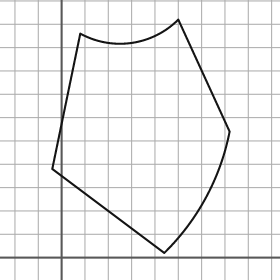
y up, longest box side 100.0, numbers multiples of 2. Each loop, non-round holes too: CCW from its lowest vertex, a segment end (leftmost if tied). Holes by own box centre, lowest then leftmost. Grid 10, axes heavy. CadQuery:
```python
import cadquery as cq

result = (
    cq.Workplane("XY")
    .moveTo(44.0, 2.0)
    .threePointArc((62.0, 26.0), (72.0, 54.0))
    .lineTo(50.0, 102.0)
    .threePointArc((30.0, 92.0), (8.0, 96.0))
    .lineTo(-4.0, 38.0)
    .close()
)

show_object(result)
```